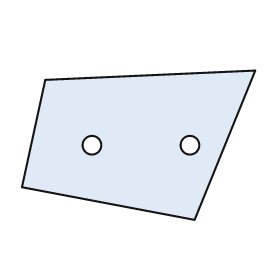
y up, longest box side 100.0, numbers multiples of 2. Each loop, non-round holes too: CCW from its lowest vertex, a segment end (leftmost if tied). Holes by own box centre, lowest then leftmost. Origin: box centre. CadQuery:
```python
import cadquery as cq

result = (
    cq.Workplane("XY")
    .moveTo(24.0, -32.0)
    .lineTo(50.0, 32.0)
    .lineTo(-40.0, 28.0)
    .lineTo(-50.0, -18.0)
    .close()
    .moveTo(-20.0, 0.0)
    .circle(4.0)
    .moveTo(22.0, 0.0)
    .circle(4.0)
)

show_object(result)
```